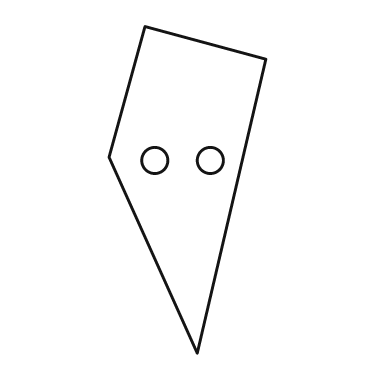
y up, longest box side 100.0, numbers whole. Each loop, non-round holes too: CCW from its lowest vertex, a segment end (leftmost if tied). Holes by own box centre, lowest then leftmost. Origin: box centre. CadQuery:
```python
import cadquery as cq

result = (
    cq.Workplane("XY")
    .moveTo(3.0, -50.0)
    .lineTo(24.0, 40.0)
    .lineTo(-13.0, 50.0)
    .lineTo(-24.0, 10.0)
    .close()
    .moveTo(-10.0, 9.0)
    .circle(4.0)
    .moveTo(7.0, 9.0)
    .circle(4.0)
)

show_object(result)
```